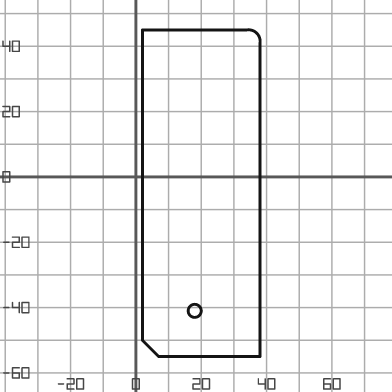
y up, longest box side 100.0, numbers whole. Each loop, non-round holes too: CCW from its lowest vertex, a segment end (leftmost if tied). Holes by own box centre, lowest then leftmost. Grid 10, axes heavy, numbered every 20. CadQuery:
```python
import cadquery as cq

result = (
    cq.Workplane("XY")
    .moveTo(7.0, -55.0)
    .lineTo(38.0, -55.0)
    .lineTo(38.0, 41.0)
    .threePointArc((37.0, 44.0), (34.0, 45.0))
    .lineTo(2.0, 45.0)
    .lineTo(2.0, -50.0)
    .close()
    .moveTo(18.0, -41.0)
    .circle(2.0)
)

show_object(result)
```